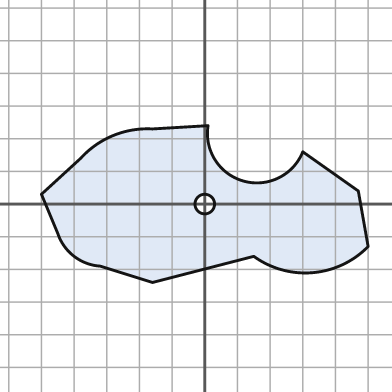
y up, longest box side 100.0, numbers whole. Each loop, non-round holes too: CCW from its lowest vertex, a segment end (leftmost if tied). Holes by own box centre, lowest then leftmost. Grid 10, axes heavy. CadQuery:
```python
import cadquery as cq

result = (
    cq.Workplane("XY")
    .moveTo(-16.0, -24.0)
    .lineTo(15.0, -16.0)
    .threePointArc((33.0, -21.0), (50.0, -13.0))
    .lineTo(47.0, 4.0)
    .lineTo(30.0, 16.0)
    .threePointArc((12.0, 7.0), (1.0, 24.0))
    .lineTo(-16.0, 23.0)
    .threePointArc((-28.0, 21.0), (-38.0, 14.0))
    .lineTo(-50.0, 3.0)
    .lineTo(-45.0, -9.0)
    .threePointArc((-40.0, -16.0), (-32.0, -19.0))
    .close()
    .moveTo(0.0, 0.0)
    .circle(3.0)
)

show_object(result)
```